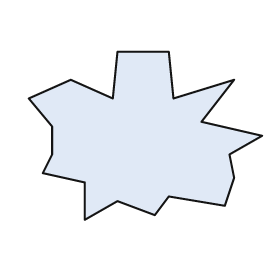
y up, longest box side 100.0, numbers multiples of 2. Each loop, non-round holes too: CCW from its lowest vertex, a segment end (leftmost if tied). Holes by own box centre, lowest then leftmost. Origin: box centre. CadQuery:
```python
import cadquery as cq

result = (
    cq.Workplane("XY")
    .moveTo(-26.0, -36.0)
    .lineTo(-12.0, -28.0)
    .lineTo(4.0, -34.0)
    .lineTo(10.0, -26.0)
    .lineTo(34.0, -30.0)
    .lineTo(38.0, -18.0)
    .lineTo(36.0, -8.0)
    .lineTo(50.0, 0.0)
    .lineTo(24.0, 6.0)
    .lineTo(38.0, 24.0)
    .lineTo(12.0, 16.0)
    .lineTo(10.0, 36.0)
    .lineTo(-12.0, 36.0)
    .lineTo(-14.0, 16.0)
    .lineTo(-32.0, 24.0)
    .lineTo(-50.0, 16.0)
    .lineTo(-40.0, 4.0)
    .lineTo(-40.0, -8.0)
    .lineTo(-44.0, -16.0)
    .lineTo(-26.0, -20.0)
    .close()
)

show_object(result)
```